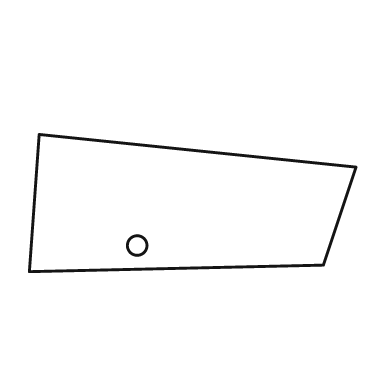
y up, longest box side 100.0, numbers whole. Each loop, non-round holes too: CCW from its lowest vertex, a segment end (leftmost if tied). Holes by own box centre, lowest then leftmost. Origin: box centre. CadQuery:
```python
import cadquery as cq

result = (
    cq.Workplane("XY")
    .moveTo(-50.0, -21.0)
    .lineTo(40.0, -19.0)
    .lineTo(50.0, 11.0)
    .lineTo(-47.0, 21.0)
    .close()
    .moveTo(-17.0, -13.0)
    .circle(3.0)
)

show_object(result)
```